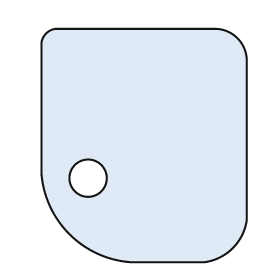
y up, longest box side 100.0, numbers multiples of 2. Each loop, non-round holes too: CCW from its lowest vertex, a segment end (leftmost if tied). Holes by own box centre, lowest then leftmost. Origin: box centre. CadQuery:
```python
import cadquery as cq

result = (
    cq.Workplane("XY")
    .moveTo(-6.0, -50.0)
    .lineTo(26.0, -50.0)
    .threePointArc((38.0, -44.0), (44.0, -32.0))
    .lineTo(44.0, 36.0)
    .threePointArc((40.0, 46.0), (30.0, 50.0))
    .lineTo(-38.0, 50.0)
    .threePointArc((-42.0, 48.0), (-44.0, 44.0))
    .lineTo(-44.0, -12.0)
    .threePointArc((-32.0, -38.0), (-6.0, -50.0))
    .close()
    .moveTo(-24.0, -14.0)
    .circle(8.0)
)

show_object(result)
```